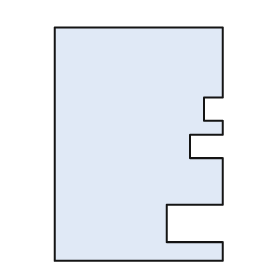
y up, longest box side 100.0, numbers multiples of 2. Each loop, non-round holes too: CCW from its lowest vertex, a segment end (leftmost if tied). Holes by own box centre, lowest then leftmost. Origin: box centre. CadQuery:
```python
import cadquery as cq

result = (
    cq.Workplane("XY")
    .moveTo(-36.0, -50.0)
    .lineTo(36.0, -50.0)
    .lineTo(36.0, -42.0)
    .lineTo(12.0, -42.0)
    .lineTo(12.0, -26.0)
    .lineTo(36.0, -26.0)
    .lineTo(36.0, -6.0)
    .lineTo(22.0, -6.0)
    .lineTo(22.0, 4.0)
    .lineTo(36.0, 4.0)
    .lineTo(36.0, 10.0)
    .lineTo(28.0, 10.0)
    .lineTo(28.0, 20.0)
    .lineTo(36.0, 20.0)
    .lineTo(36.0, 50.0)
    .lineTo(-36.0, 50.0)
    .close()
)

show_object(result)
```